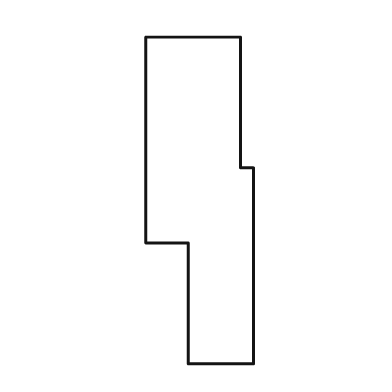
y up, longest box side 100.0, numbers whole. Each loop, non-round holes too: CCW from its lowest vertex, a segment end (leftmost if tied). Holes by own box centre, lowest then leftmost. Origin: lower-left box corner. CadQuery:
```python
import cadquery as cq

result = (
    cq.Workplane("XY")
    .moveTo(13.0, 0.0)
    .lineTo(33.0, 0.0)
    .lineTo(33.0, 60.0)
    .lineTo(29.0, 60.0)
    .lineTo(29.0, 100.0)
    .lineTo(0.0, 100.0)
    .lineTo(0.0, 37.0)
    .lineTo(13.0, 37.0)
    .close()
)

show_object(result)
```